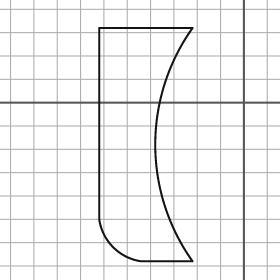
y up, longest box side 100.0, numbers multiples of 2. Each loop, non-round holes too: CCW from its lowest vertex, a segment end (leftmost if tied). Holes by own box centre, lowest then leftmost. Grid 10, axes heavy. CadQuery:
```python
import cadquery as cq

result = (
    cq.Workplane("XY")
    .moveTo(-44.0, -68.0)
    .lineTo(-22.0, -68.0)
    .threePointArc((-38.0, -18.0), (-22.0, 32.0))
    .lineTo(-62.0, 32.0)
    .lineTo(-62.0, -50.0)
    .threePointArc((-56.0, -62.0), (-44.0, -68.0))
    .close()
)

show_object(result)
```